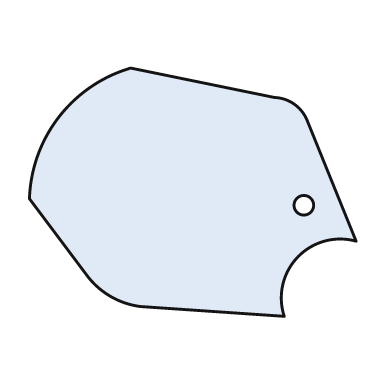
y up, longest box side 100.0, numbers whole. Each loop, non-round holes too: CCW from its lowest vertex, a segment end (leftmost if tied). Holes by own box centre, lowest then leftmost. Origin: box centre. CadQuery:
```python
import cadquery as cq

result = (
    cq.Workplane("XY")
    .moveTo(28.0, -38.0)
    .threePointArc((32.0, -20.0), (50.0, -15.0))
    .lineTo(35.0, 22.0)
    .threePointArc((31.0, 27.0), (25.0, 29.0))
    .lineTo(-19.0, 38.0)
    .threePointArc((-41.0, 23.0), (-50.0, -2.0))
    .lineTo(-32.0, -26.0)
    .threePointArc((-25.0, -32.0), (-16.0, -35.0))
    .close()
    .moveTo(34.0, -4.0)
    .circle(3.0)
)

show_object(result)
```